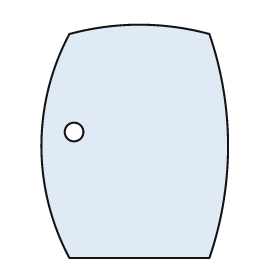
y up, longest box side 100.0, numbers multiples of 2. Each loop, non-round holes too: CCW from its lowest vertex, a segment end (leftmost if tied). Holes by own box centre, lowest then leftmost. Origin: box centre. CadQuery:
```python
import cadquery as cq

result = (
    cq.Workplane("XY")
    .moveTo(-28.0, -50.0)
    .lineTo(32.0, -50.0)
    .threePointArc((40.0, -2.0), (32.0, 46.0))
    .threePointArc((2.0, 50.0), (-28.0, 46.0))
    .threePointArc((-40.0, -2.0), (-28.0, -50.0))
    .close()
    .moveTo(-26.0, 4.0)
    .circle(4.0)
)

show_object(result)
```